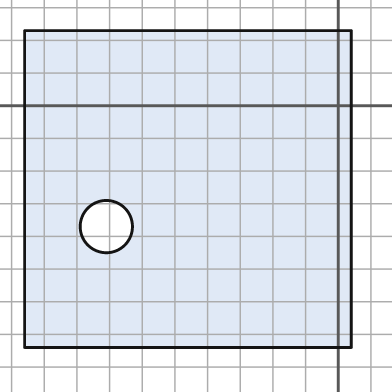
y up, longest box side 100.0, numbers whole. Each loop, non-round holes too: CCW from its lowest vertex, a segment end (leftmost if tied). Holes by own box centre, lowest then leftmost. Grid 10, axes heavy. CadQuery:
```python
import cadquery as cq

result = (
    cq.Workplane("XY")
    .moveTo(-96.0, -74.0)
    .lineTo(4.0, -74.0)
    .lineTo(4.0, 23.0)
    .lineTo(-96.0, 23.0)
    .close()
    .moveTo(-71.0, -37.0)
    .circle(8.0)
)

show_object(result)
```